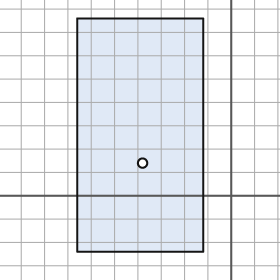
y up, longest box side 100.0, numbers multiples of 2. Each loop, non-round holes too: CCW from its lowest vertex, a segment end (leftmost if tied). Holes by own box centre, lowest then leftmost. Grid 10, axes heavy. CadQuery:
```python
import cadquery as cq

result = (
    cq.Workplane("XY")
    .moveTo(-66.0, -24.0)
    .lineTo(-12.0, -24.0)
    .lineTo(-12.0, 76.0)
    .lineTo(-66.0, 76.0)
    .close()
    .moveTo(-38.0, 14.0)
    .circle(2.0)
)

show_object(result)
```